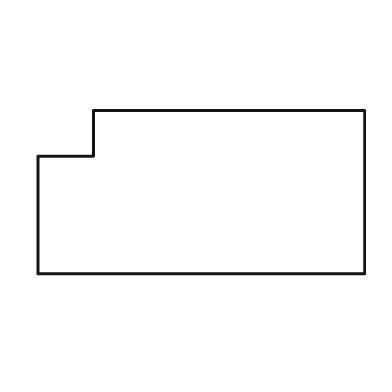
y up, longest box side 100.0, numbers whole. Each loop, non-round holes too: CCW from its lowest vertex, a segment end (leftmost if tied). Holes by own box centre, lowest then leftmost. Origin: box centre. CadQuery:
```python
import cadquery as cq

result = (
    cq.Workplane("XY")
    .moveTo(-50.0, -25.0)
    .lineTo(50.0, -25.0)
    .lineTo(50.0, 25.0)
    .lineTo(-33.0, 25.0)
    .lineTo(-33.0, 11.0)
    .lineTo(-50.0, 11.0)
    .close()
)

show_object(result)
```